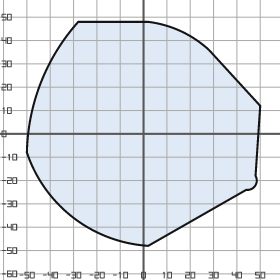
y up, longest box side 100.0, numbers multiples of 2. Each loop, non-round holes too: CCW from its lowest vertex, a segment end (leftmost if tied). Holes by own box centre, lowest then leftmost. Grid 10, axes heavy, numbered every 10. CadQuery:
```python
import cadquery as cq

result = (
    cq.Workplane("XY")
    .moveTo(2.0, -48.0)
    .lineTo(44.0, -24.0)
    .threePointArc((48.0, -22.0), (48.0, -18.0))
    .lineTo(50.0, 12.0)
    .lineTo(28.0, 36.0)
    .threePointArc((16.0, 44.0), (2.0, 48.0))
    .lineTo(-28.0, 48.0)
    .threePointArc((-44.0, 22.0), (-50.0, -8.0))
    .threePointArc((-30.0, -36.0), (2.0, -48.0))
    .close()
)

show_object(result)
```